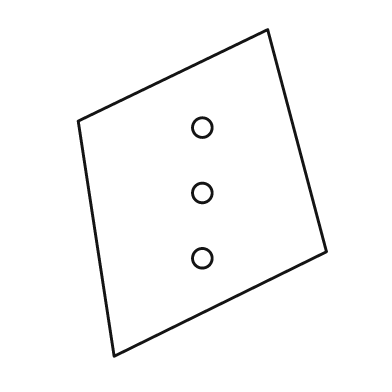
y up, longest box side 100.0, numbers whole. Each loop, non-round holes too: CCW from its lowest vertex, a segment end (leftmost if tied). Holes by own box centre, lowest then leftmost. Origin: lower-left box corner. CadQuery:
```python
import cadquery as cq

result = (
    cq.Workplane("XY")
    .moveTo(11.0, 0.0)
    .lineTo(76.0, 32.0)
    .lineTo(58.0, 100.0)
    .lineTo(0.0, 72.0)
    .close()
    .moveTo(38.0, 30.0)
    .circle(3.0)
    .moveTo(38.0, 50.0)
    .circle(3.0)
    .moveTo(38.0, 70.0)
    .circle(3.0)
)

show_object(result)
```